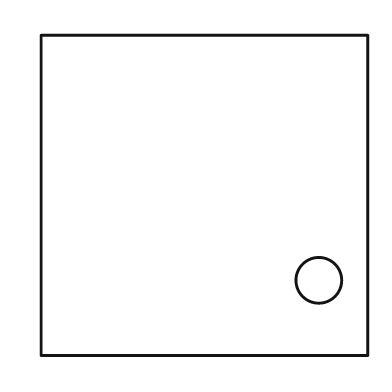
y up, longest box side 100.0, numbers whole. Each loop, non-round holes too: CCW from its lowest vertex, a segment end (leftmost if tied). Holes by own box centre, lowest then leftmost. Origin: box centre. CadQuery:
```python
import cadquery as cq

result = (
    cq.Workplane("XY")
    .moveTo(-50.0, -49.0)
    .lineTo(50.0, -49.0)
    .lineTo(50.0, 49.0)
    .lineTo(-50.0, 49.0)
    .close()
    .moveTo(35.0, -26.0)
    .circle(7.0)
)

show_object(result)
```